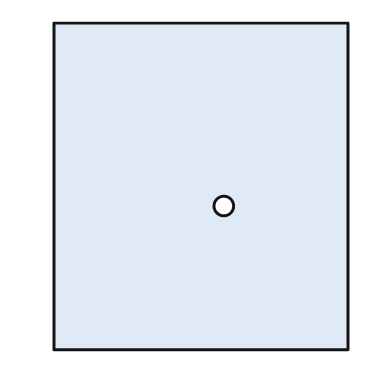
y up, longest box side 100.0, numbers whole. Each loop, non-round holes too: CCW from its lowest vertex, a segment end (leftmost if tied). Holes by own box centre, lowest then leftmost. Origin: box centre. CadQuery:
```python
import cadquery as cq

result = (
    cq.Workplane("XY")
    .moveTo(-45.0, -50.0)
    .lineTo(45.0, -50.0)
    .lineTo(45.0, 50.0)
    .lineTo(-45.0, 50.0)
    .close()
    .moveTo(7.0, -6.0)
    .circle(3.0)
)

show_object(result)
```